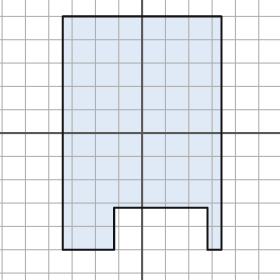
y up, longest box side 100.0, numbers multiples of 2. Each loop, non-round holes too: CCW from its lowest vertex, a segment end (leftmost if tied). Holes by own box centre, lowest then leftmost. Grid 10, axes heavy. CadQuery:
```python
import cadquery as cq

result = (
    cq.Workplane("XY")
    .moveTo(-34.0, -50.0)
    .lineTo(-12.0, -50.0)
    .lineTo(-12.0, -32.0)
    .lineTo(28.0, -32.0)
    .lineTo(28.0, -50.0)
    .lineTo(34.0, -50.0)
    .lineTo(34.0, 50.0)
    .lineTo(-34.0, 50.0)
    .close()
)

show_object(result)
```